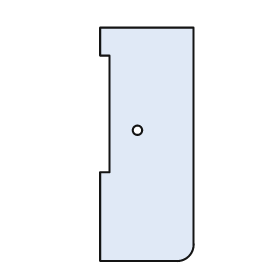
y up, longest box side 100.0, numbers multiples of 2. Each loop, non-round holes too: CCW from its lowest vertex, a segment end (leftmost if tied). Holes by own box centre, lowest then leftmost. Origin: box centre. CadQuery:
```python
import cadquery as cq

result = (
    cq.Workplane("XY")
    .moveTo(-20.0, -50.0)
    .lineTo(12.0, -50.0)
    .threePointArc((18.0, -48.0), (20.0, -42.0))
    .lineTo(20.0, 50.0)
    .lineTo(-20.0, 50.0)
    .lineTo(-20.0, 38.0)
    .lineTo(-16.0, 38.0)
    .lineTo(-16.0, -12.0)
    .lineTo(-20.0, -12.0)
    .close()
    .moveTo(-4.0, 6.0)
    .circle(2.0)
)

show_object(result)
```